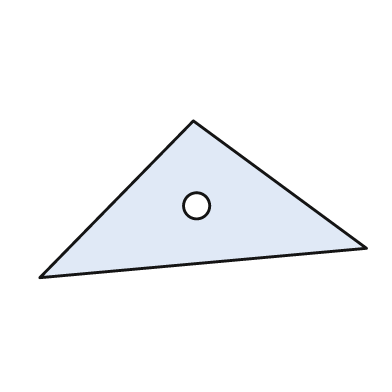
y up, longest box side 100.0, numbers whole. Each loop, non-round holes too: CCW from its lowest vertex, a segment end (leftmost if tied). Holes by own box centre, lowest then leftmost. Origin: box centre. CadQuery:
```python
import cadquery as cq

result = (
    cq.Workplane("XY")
    .moveTo(-50.0, -24.0)
    .lineTo(50.0, -15.0)
    .lineTo(-3.0, 24.0)
    .close()
    .moveTo(-2.0, -2.0)
    .circle(4.0)
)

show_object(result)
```